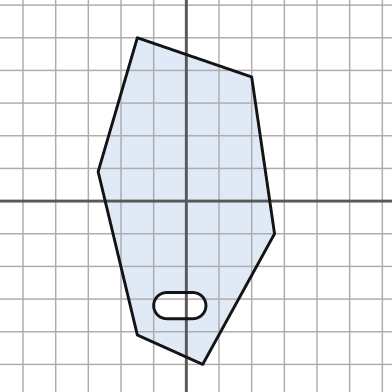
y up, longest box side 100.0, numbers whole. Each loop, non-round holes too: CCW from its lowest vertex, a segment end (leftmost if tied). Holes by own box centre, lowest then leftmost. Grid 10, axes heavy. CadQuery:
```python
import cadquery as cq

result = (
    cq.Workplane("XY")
    .moveTo(5.0, -50.0)
    .lineTo(27.0, -10.0)
    .lineTo(20.0, 38.0)
    .lineTo(-15.0, 50.0)
    .lineTo(-27.0, 9.0)
    .lineTo(-15.0, -41.0)
    .close()
    .moveTo(-6.0, -36.0)
    .lineTo(2.0, -36.0)
    .threePointArc((6.0, -32.0), (2.0, -28.0))
    .lineTo(-6.0, -28.0)
    .threePointArc((-10.0, -32.0), (-6.0, -36.0))
    .close()
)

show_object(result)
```